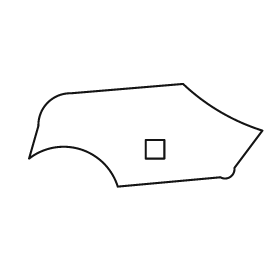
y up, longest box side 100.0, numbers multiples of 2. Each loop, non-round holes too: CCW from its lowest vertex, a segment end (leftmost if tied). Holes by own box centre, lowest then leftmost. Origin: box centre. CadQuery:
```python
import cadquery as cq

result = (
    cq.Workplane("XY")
    .moveTo(-12.0, -22.0)
    .lineTo(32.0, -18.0)
    .threePointArc((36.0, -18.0), (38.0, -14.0))
    .lineTo(50.0, 2.0)
    .threePointArc((32.0, 10.0), (16.0, 22.0))
    .lineTo(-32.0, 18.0)
    .threePointArc((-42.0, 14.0), (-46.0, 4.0))
    .lineTo(-50.0, -10.0)
    .threePointArc((-28.0, -6.0), (-12.0, -22.0))
    .close()
    .moveTo(0.0, -10.0)
    .lineTo(8.0, -10.0)
    .lineTo(8.0, -2.0)
    .lineTo(0.0, -2.0)
    .close()
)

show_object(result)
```